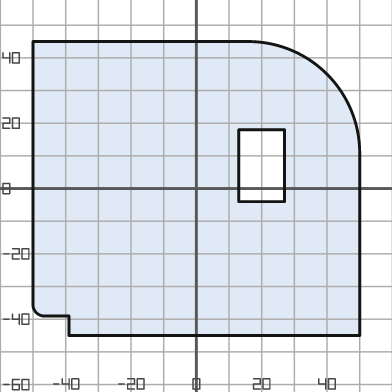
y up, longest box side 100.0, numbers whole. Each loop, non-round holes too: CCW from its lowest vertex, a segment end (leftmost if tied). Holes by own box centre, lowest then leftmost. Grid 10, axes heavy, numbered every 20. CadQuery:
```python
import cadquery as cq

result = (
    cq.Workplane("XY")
    .moveTo(-39.0, -45.0)
    .lineTo(50.0, -45.0)
    .lineTo(50.0, 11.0)
    .threePointArc((40.0, 35.0), (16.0, 45.0))
    .lineTo(-50.0, 45.0)
    .lineTo(-50.0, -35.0)
    .threePointArc((-49.0, -38.0), (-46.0, -39.0))
    .lineTo(-39.0, -39.0)
    .close()
    .moveTo(13.0, -4.0)
    .lineTo(27.0, -4.0)
    .lineTo(27.0, 18.0)
    .lineTo(13.0, 18.0)
    .close()
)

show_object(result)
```